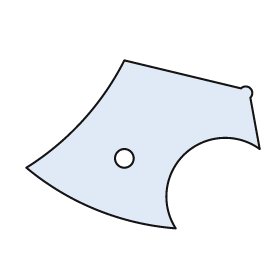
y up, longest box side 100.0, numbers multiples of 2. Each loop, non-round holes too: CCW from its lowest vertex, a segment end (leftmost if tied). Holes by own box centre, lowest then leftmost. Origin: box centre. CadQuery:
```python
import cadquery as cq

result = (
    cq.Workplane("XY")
    .moveTo(14.0, -36.0)
    .threePointArc((18.0, -4.0), (50.0, -2.0))
    .lineTo(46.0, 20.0)
    .threePointArc((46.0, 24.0), (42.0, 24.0))
    .lineTo(-8.0, 36.0)
    .threePointArc((-26.0, 10.0), (-50.0, -10.0))
    .threePointArc((-20.0, -28.0), (14.0, -36.0))
    .close()
    .moveTo(-8.0, -6.0)
    .circle(4.0)
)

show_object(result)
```